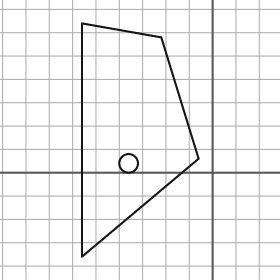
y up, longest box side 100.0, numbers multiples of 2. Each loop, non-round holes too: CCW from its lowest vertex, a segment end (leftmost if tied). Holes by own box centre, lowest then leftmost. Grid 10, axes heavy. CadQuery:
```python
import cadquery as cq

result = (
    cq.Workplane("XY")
    .moveTo(-56.0, -36.0)
    .lineTo(-6.0, 6.0)
    .lineTo(-22.0, 58.0)
    .lineTo(-56.0, 64.0)
    .close()
    .moveTo(-36.0, 4.0)
    .circle(4.0)
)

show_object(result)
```